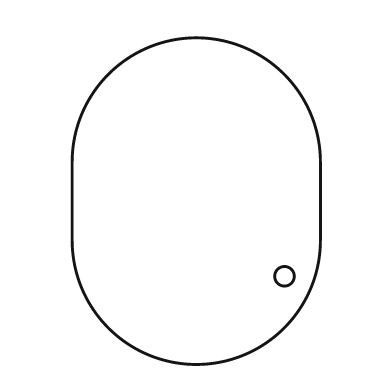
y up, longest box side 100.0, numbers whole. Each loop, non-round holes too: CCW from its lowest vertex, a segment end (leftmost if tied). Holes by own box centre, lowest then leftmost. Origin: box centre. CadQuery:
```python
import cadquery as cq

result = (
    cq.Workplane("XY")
    .moveTo(-38.0, -12.0)
    .threePointArc((0.0, -50.0), (38.0, -12.0))
    .lineTo(38.0, 12.0)
    .threePointArc((0.0, 50.0), (-38.0, 12.0))
    .close()
    .moveTo(27.0, -23.0)
    .circle(3.0)
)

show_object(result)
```